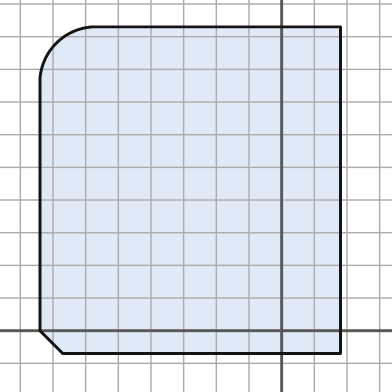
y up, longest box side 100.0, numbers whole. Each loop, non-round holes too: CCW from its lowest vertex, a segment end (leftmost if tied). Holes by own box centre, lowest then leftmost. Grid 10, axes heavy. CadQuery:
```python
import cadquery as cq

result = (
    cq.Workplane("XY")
    .moveTo(-67.0, -7.0)
    .lineTo(18.0, -7.0)
    .lineTo(18.0, 93.0)
    .lineTo(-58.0, 93.0)
    .threePointArc((-69.0, 88.0), (-74.0, 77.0))
    .lineTo(-74.0, 0.0)
    .close()
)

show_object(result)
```